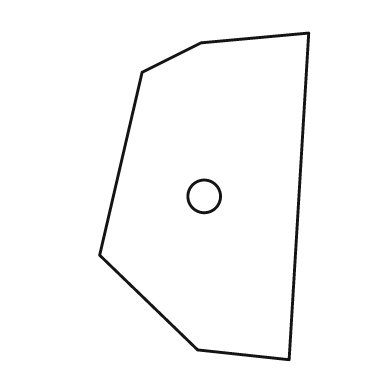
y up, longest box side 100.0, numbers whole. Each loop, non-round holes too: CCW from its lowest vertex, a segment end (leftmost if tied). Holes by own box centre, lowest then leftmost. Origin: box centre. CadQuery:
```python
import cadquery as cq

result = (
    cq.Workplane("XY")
    .moveTo(26.0, -50.0)
    .lineTo(32.0, 50.0)
    .lineTo(-1.0, 47.0)
    .lineTo(-19.0, 38.0)
    .lineTo(-32.0, -18.0)
    .lineTo(-2.0, -47.0)
    .close()
    .moveTo(0.0, 0.0)
    .circle(5.0)
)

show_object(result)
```